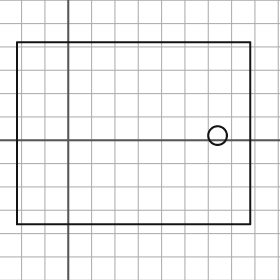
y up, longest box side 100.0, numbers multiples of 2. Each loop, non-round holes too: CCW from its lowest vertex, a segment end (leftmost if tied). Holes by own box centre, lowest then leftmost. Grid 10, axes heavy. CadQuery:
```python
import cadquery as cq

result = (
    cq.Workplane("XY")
    .moveTo(-22.0, -36.0)
    .lineTo(78.0, -36.0)
    .lineTo(78.0, 42.0)
    .lineTo(-22.0, 42.0)
    .close()
    .moveTo(64.0, 2.0)
    .circle(4.0)
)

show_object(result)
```